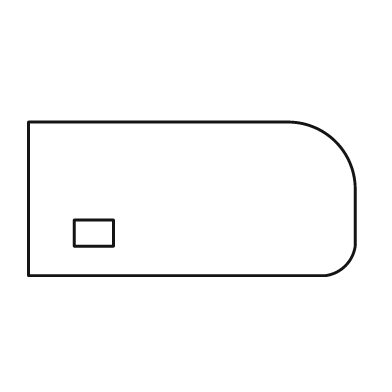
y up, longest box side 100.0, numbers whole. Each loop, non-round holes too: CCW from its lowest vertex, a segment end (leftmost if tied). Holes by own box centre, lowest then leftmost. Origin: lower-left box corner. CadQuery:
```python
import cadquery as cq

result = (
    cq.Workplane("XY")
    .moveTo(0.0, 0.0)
    .lineTo(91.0, 0.0)
    .threePointArc((97.0, 3.0), (100.0, 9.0))
    .lineTo(100.0, 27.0)
    .threePointArc((94.0, 41.0), (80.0, 47.0))
    .lineTo(0.0, 47.0)
    .close()
    .moveTo(14.0, 9.0)
    .lineTo(26.0, 9.0)
    .lineTo(26.0, 17.0)
    .lineTo(14.0, 17.0)
    .close()
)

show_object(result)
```